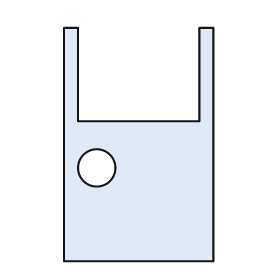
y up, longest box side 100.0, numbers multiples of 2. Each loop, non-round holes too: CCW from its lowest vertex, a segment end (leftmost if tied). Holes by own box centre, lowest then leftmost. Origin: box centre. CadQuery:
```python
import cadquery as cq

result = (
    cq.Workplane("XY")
    .moveTo(-32.0, -50.0)
    .lineTo(32.0, -50.0)
    .lineTo(32.0, 50.0)
    .lineTo(26.0, 50.0)
    .lineTo(26.0, 10.0)
    .lineTo(-26.0, 10.0)
    .lineTo(-26.0, 50.0)
    .lineTo(-32.0, 50.0)
    .close()
    .moveTo(-18.0, -10.0)
    .circle(8.0)
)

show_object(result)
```